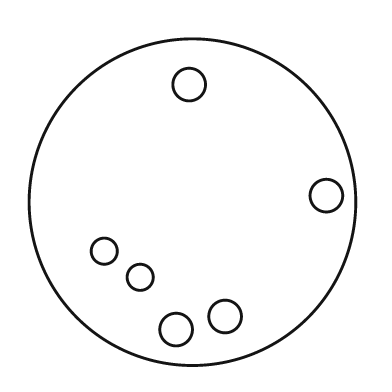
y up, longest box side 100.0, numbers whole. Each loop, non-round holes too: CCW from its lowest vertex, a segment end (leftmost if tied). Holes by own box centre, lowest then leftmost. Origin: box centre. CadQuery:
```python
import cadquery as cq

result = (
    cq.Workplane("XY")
    .moveTo(0.0, 0.0)
    .circle(50.0)
    .moveTo(-5.0, -39.0)
    .circle(5.0)
    .moveTo(10.0, -35.0)
    .circle(5.0)
    .moveTo(-16.0, -23.0)
    .circle(4.0)
    .moveTo(-27.0, -15.0)
    .circle(4.0)
    .moveTo(41.0, 2.0)
    .circle(5.0)
    .moveTo(-1.0, 36.0)
    .circle(5.0)
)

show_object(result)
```